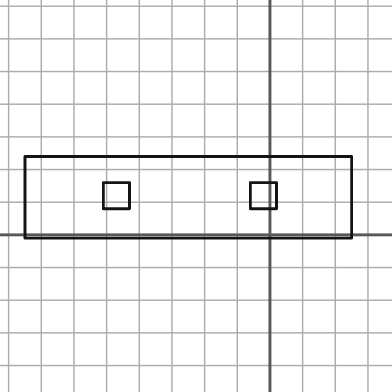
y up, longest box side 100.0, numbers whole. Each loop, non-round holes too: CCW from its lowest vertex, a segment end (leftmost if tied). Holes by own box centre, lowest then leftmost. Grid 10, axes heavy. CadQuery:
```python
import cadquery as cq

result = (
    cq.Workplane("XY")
    .moveTo(-75.0, -1.0)
    .lineTo(25.0, -1.0)
    .lineTo(25.0, 24.0)
    .lineTo(-75.0, 24.0)
    .close()
    .moveTo(-51.0, 8.0)
    .lineTo(-43.0, 8.0)
    .lineTo(-43.0, 16.0)
    .lineTo(-51.0, 16.0)
    .close()
    .moveTo(-6.0, 8.0)
    .lineTo(2.0, 8.0)
    .lineTo(2.0, 16.0)
    .lineTo(-6.0, 16.0)
    .close()
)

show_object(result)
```